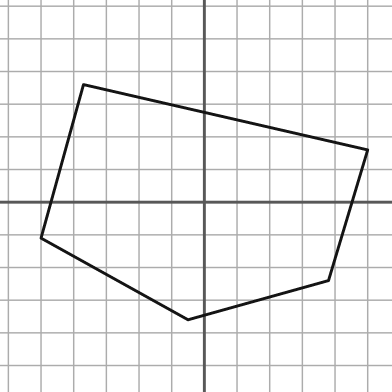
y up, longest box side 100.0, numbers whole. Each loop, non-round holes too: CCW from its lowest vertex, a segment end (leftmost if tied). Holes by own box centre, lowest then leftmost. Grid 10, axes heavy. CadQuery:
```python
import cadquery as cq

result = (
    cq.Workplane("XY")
    .moveTo(-5.0, -36.0)
    .lineTo(38.0, -24.0)
    .lineTo(50.0, 16.0)
    .lineTo(-37.0, 36.0)
    .lineTo(-50.0, -11.0)
    .close()
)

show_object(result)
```